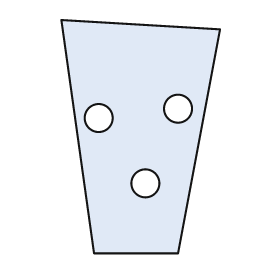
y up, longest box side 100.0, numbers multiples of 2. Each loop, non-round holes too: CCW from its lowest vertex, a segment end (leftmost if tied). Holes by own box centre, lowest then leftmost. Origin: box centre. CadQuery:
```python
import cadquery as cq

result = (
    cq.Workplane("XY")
    .moveTo(-20.0, -50.0)
    .lineTo(16.0, -50.0)
    .lineTo(34.0, 46.0)
    .lineTo(-34.0, 50.0)
    .close()
    .moveTo(2.0, -20.0)
    .circle(6.0)
    .moveTo(-18.0, 8.0)
    .circle(6.0)
    .moveTo(16.0, 12.0)
    .circle(6.0)
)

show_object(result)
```